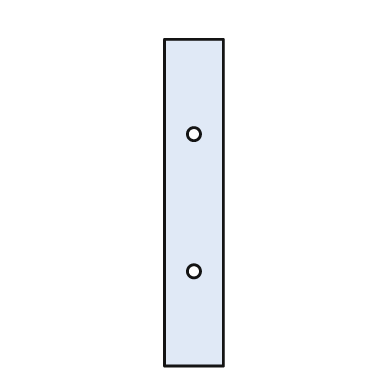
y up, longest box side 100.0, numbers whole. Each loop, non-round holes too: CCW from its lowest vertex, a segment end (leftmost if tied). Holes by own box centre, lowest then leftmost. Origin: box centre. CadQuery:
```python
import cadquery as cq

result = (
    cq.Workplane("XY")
    .moveTo(-9.0, -50.0)
    .lineTo(9.0, -50.0)
    .lineTo(9.0, 50.0)
    .lineTo(-9.0, 50.0)
    .close()
    .moveTo(0.0, -21.0)
    .circle(2.0)
    .moveTo(0.0, 21.0)
    .circle(2.0)
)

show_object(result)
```